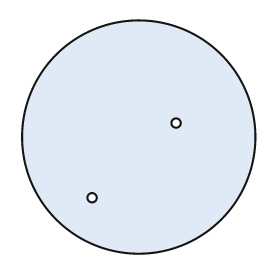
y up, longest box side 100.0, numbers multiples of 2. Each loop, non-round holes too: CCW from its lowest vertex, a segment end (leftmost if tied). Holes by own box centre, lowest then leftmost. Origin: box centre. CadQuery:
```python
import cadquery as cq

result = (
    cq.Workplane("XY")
    .moveTo(0.0, 0.0)
    .circle(50.0)
    .moveTo(-20.0, -26.0)
    .circle(2.0)
    .moveTo(16.0, 6.0)
    .circle(2.0)
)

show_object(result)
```